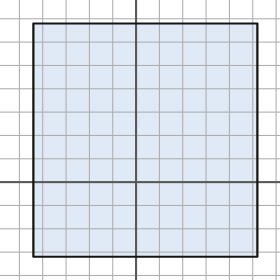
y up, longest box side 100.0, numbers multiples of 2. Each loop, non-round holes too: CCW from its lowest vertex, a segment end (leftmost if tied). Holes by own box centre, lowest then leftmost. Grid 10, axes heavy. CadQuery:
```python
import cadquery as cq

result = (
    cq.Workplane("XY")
    .moveTo(-44.0, -32.0)
    .lineTo(52.0, -32.0)
    .lineTo(52.0, 68.0)
    .lineTo(-44.0, 68.0)
    .close()
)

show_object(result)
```